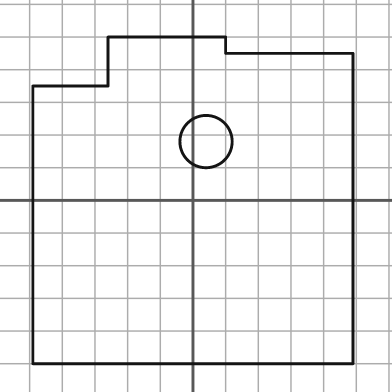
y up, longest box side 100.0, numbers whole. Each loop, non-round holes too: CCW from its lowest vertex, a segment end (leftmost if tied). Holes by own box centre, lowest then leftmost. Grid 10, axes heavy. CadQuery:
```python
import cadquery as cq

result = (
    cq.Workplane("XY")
    .moveTo(-49.0, -50.0)
    .lineTo(49.0, -50.0)
    .lineTo(49.0, 45.0)
    .lineTo(10.0, 45.0)
    .lineTo(10.0, 50.0)
    .lineTo(-26.0, 50.0)
    .lineTo(-26.0, 35.0)
    .lineTo(-49.0, 35.0)
    .close()
    .moveTo(4.0, 18.0)
    .circle(8.0)
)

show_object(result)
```